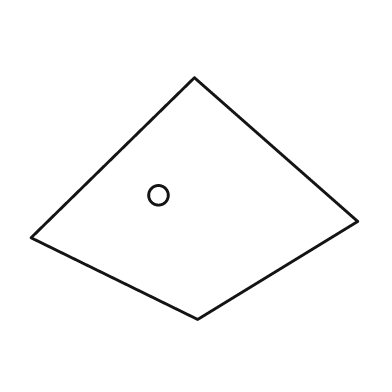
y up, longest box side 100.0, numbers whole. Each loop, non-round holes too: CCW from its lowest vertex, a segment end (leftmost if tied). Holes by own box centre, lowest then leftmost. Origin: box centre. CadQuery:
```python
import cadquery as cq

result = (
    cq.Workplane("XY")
    .moveTo(1.0, -37.0)
    .lineTo(50.0, -7.0)
    .lineTo(0.0, 37.0)
    .lineTo(-50.0, -12.0)
    .close()
    .moveTo(-11.0, 1.0)
    .circle(3.0)
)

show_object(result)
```